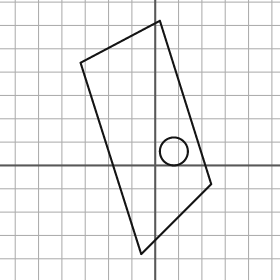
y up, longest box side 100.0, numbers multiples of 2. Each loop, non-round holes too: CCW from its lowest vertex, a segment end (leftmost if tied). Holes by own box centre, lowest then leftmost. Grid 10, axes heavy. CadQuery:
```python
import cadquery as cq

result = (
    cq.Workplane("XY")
    .moveTo(-6.0, -38.0)
    .lineTo(24.0, -8.0)
    .lineTo(2.0, 62.0)
    .lineTo(-32.0, 44.0)
    .close()
    .moveTo(8.0, 6.0)
    .circle(6.0)
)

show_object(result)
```